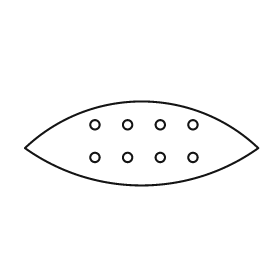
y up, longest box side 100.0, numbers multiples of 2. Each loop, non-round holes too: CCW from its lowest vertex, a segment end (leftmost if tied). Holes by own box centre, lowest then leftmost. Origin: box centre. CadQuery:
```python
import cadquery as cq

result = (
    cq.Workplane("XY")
    .moveTo(-50.0, -2.0)
    .threePointArc((0.0, -18.0), (50.0, -2.0))
    .threePointArc((0.0, 18.0), (-50.0, -2.0))
    .close()
    .moveTo(-20.0, -6.0)
    .circle(2.0)
    .moveTo(-6.0, -6.0)
    .circle(2.0)
    .moveTo(8.0, -6.0)
    .circle(2.0)
    .moveTo(22.0, -6.0)
    .circle(2.0)
    .moveTo(-20.0, 8.0)
    .circle(2.0)
    .moveTo(-6.0, 8.0)
    .circle(2.0)
    .moveTo(8.0, 8.0)
    .circle(2.0)
    .moveTo(22.0, 8.0)
    .circle(2.0)
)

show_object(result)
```